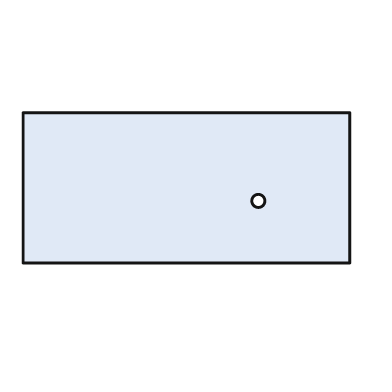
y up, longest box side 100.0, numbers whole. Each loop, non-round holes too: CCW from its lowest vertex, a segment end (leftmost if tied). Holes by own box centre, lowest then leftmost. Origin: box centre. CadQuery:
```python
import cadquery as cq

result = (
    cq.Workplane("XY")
    .moveTo(-50.0, -23.0)
    .lineTo(50.0, -23.0)
    .lineTo(50.0, 23.0)
    .lineTo(-50.0, 23.0)
    .close()
    .moveTo(22.0, -4.0)
    .circle(2.0)
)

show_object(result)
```